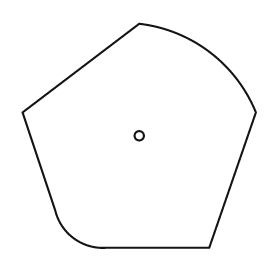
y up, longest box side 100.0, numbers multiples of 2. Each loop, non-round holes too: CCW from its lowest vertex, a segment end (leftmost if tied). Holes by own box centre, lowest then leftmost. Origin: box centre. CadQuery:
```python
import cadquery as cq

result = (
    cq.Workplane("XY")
    .moveTo(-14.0, -48.0)
    .lineTo(30.0, -48.0)
    .lineTo(50.0, 10.0)
    .threePointArc((30.0, 36.0), (0.0, 48.0))
    .lineTo(-50.0, 10.0)
    .lineTo(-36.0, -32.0)
    .threePointArc((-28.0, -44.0), (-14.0, -48.0))
    .close()
    .moveTo(0.0, 0.0)
    .circle(2.0)
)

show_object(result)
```